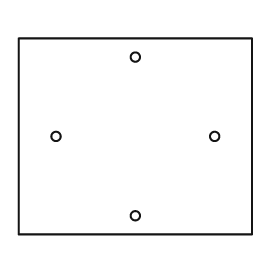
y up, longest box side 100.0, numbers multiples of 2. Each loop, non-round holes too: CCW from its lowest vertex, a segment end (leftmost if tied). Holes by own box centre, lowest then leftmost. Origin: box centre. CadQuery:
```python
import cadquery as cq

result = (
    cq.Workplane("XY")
    .moveTo(-50.0, -42.0)
    .lineTo(50.0, -42.0)
    .lineTo(50.0, 42.0)
    .lineTo(-50.0, 42.0)
    .close()
    .moveTo(0.0, -34.0)
    .circle(2.0)
    .moveTo(-34.0, 0.0)
    .circle(2.0)
    .moveTo(34.0, 0.0)
    .circle(2.0)
    .moveTo(0.0, 34.0)
    .circle(2.0)
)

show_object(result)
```